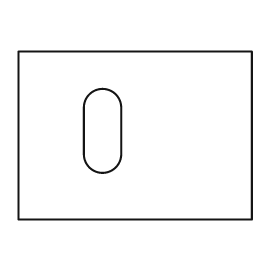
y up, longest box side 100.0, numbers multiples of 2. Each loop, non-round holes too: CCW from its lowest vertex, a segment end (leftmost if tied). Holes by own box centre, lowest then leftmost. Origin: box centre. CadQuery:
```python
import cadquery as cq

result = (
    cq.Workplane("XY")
    .moveTo(-50.0, -36.0)
    .lineTo(50.0, -36.0)
    .lineTo(50.0, 36.0)
    .lineTo(-50.0, 36.0)
    .close()
    .moveTo(-22.0, -8.0)
    .threePointArc((-14.0, -16.0), (-6.0, -8.0))
    .lineTo(-6.0, 12.0)
    .threePointArc((-14.0, 20.0), (-22.0, 12.0))
    .close()
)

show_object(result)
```